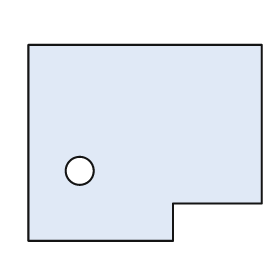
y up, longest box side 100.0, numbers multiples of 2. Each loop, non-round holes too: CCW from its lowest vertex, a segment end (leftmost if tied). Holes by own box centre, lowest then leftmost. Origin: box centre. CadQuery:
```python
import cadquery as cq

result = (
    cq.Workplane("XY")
    .moveTo(-50.0, -42.0)
    .lineTo(12.0, -42.0)
    .lineTo(12.0, -26.0)
    .lineTo(50.0, -26.0)
    .lineTo(50.0, 42.0)
    .lineTo(-50.0, 42.0)
    .close()
    .moveTo(-28.0, -12.0)
    .circle(6.0)
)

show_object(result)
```